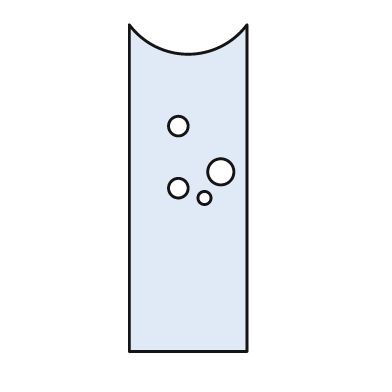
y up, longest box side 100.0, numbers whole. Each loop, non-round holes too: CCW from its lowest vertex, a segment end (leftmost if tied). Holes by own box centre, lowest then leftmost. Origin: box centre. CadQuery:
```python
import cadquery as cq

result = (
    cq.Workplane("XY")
    .moveTo(-18.0, -50.0)
    .lineTo(18.0, -50.0)
    .lineTo(18.0, 50.0)
    .threePointArc((0.0, 41.0), (-18.0, 50.0))
    .close()
    .moveTo(5.0, -3.0)
    .circle(2.0)
    .moveTo(-3.0, 0.0)
    .circle(3.0)
    .moveTo(10.0, 5.0)
    .circle(4.0)
    .moveTo(-3.0, 19.0)
    .circle(3.0)
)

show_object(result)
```